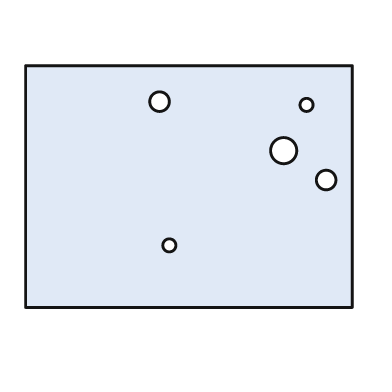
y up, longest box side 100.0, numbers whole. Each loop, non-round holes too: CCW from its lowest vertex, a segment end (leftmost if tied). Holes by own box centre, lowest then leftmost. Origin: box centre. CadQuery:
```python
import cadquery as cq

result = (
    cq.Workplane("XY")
    .moveTo(-50.0, -37.0)
    .lineTo(50.0, -37.0)
    .lineTo(50.0, 37.0)
    .lineTo(-50.0, 37.0)
    .close()
    .moveTo(-6.0, -18.0)
    .circle(2.0)
    .moveTo(42.0, 2.0)
    .circle(3.0)
    .moveTo(29.0, 11.0)
    .circle(4.0)
    .moveTo(36.0, 25.0)
    .circle(2.0)
    .moveTo(-9.0, 26.0)
    .circle(3.0)
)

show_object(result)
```